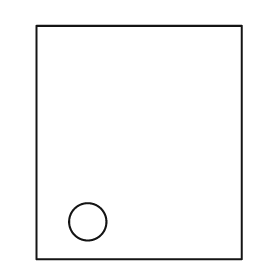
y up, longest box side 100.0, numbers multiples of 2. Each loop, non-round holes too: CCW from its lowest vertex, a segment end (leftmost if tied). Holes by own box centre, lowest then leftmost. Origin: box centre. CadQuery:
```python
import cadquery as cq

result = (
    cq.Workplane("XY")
    .moveTo(-44.0, -50.0)
    .lineTo(44.0, -50.0)
    .lineTo(44.0, 50.0)
    .lineTo(-44.0, 50.0)
    .close()
    .moveTo(-22.0, -34.0)
    .circle(8.0)
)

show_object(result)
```